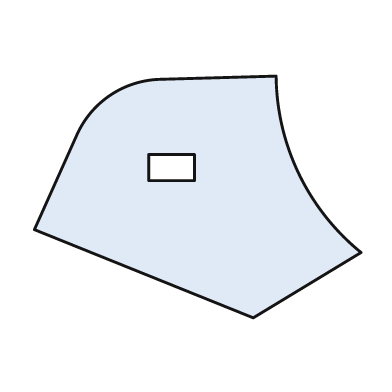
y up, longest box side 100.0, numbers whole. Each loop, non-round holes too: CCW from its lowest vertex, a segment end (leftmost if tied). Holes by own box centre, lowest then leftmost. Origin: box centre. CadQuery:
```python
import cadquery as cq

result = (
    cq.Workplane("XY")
    .moveTo(17.0, -37.0)
    .lineTo(50.0, -17.0)
    .threePointArc((31.0, 7.0), (24.0, 37.0))
    .lineTo(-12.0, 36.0)
    .threePointArc((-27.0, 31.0), (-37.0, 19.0))
    .lineTo(-50.0, -10.0)
    .close()
    .moveTo(-15.0, 5.0)
    .lineTo(-1.0, 5.0)
    .lineTo(-1.0, 13.0)
    .lineTo(-15.0, 13.0)
    .close()
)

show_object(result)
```